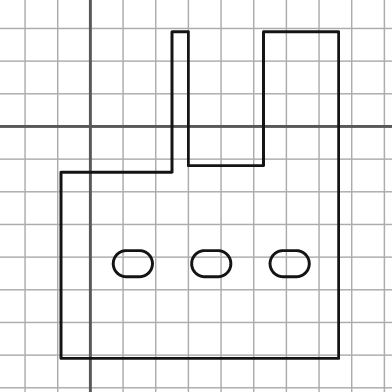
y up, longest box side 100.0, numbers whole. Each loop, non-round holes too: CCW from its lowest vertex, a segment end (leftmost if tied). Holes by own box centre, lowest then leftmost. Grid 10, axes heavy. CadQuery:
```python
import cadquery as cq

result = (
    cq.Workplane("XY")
    .moveTo(-9.0, -71.0)
    .lineTo(76.0, -71.0)
    .lineTo(76.0, 29.0)
    .lineTo(53.0, 29.0)
    .lineTo(53.0, -12.0)
    .lineTo(30.0, -12.0)
    .lineTo(30.0, 29.0)
    .lineTo(25.0, 29.0)
    .lineTo(25.0, -14.0)
    .lineTo(-9.0, -14.0)
    .close()
    .moveTo(11.0, -46.0)
    .lineTo(15.0, -46.0)
    .threePointArc((19.0, -42.0), (15.0, -38.0))
    .lineTo(11.0, -38.0)
    .threePointArc((7.0, -42.0), (11.0, -46.0))
    .close()
    .moveTo(35.0, -46.0)
    .lineTo(39.0, -46.0)
    .threePointArc((43.0, -42.0), (39.0, -38.0))
    .lineTo(35.0, -38.0)
    .threePointArc((31.0, -42.0), (35.0, -46.0))
    .close()
    .moveTo(59.0, -46.0)
    .lineTo(63.0, -46.0)
    .threePointArc((67.0, -42.0), (63.0, -38.0))
    .lineTo(59.0, -38.0)
    .threePointArc((55.0, -42.0), (59.0, -46.0))
    .close()
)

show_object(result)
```